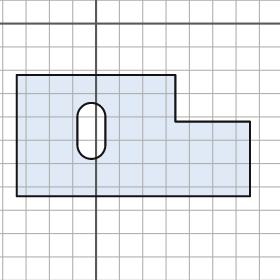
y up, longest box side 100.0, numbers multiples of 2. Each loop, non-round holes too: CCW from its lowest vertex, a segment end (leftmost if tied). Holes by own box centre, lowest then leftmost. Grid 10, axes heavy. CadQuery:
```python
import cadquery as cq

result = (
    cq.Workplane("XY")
    .moveTo(-34.0, -74.0)
    .lineTo(66.0, -74.0)
    .lineTo(66.0, -42.0)
    .lineTo(34.0, -42.0)
    .lineTo(34.0, -22.0)
    .lineTo(-34.0, -22.0)
    .close()
    .moveTo(-8.0, -52.0)
    .threePointArc((-2.0, -58.0), (4.0, -52.0))
    .lineTo(4.0, -40.0)
    .threePointArc((-2.0, -34.0), (-8.0, -40.0))
    .close()
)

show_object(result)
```